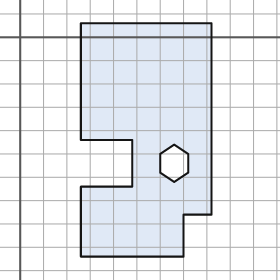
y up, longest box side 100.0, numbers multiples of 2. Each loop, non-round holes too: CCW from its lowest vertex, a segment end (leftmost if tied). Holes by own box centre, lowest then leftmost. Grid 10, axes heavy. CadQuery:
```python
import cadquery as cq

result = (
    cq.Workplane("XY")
    .moveTo(26.0, -94.0)
    .lineTo(70.0, -94.0)
    .lineTo(70.0, -76.0)
    .lineTo(82.0, -76.0)
    .lineTo(82.0, 6.0)
    .lineTo(26.0, 6.0)
    .lineTo(26.0, -44.0)
    .lineTo(48.0, -44.0)
    .lineTo(48.0, -64.0)
    .lineTo(26.0, -64.0)
    .close()
    .moveTo(66.0, -62.0)
    .lineTo(72.0, -58.0)
    .lineTo(72.0, -50.0)
    .lineTo(66.0, -46.0)
    .lineTo(60.0, -50.0)
    .lineTo(60.0, -58.0)
    .close()
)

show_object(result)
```